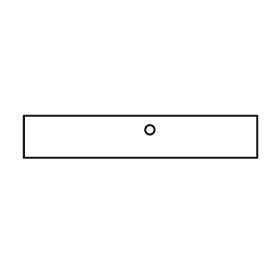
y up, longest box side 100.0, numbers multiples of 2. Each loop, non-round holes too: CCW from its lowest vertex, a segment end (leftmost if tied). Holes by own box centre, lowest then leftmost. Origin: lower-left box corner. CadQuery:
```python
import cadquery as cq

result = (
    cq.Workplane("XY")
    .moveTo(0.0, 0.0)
    .lineTo(100.0, 0.0)
    .lineTo(100.0, 18.0)
    .lineTo(0.0, 18.0)
    .close()
    .moveTo(54.0, 12.0)
    .circle(2.0)
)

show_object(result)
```